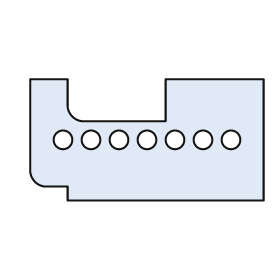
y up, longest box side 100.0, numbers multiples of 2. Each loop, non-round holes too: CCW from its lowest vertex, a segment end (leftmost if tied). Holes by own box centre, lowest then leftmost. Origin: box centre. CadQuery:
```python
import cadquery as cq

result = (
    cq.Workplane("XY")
    .moveTo(-34.0, -26.0)
    .lineTo(50.0, -26.0)
    .lineTo(50.0, 26.0)
    .lineTo(8.0, 26.0)
    .lineTo(8.0, 8.0)
    .lineTo(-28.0, 8.0)
    .threePointArc((-32.0, 10.0), (-34.0, 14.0))
    .lineTo(-34.0, 26.0)
    .lineTo(-50.0, 26.0)
    .lineTo(-50.0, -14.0)
    .threePointArc((-48.0, -18.0), (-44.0, -20.0))
    .lineTo(-34.0, -20.0)
    .close()
    .moveTo(-36.0, 0.0)
    .circle(4.0)
    .moveTo(-24.0, 0.0)
    .circle(4.0)
    .moveTo(-12.0, 0.0)
    .circle(4.0)
    .moveTo(0.0, 0.0)
    .circle(4.0)
    .moveTo(12.0, 0.0)
    .circle(4.0)
    .moveTo(24.0, 0.0)
    .circle(4.0)
    .moveTo(36.0, 0.0)
    .circle(4.0)
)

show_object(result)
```